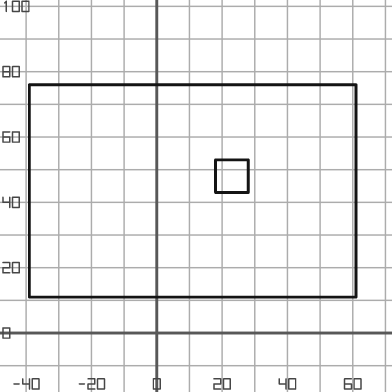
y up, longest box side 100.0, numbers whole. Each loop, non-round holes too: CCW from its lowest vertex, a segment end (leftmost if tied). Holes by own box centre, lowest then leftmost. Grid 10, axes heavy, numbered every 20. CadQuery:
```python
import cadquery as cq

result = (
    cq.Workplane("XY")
    .moveTo(-39.0, 11.0)
    .lineTo(61.0, 11.0)
    .lineTo(61.0, 76.0)
    .lineTo(-39.0, 76.0)
    .close()
    .moveTo(18.0, 43.0)
    .lineTo(28.0, 43.0)
    .lineTo(28.0, 53.0)
    .lineTo(18.0, 53.0)
    .close()
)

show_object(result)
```